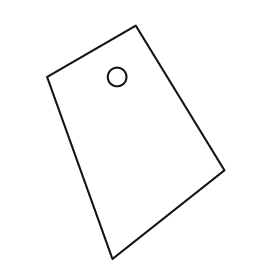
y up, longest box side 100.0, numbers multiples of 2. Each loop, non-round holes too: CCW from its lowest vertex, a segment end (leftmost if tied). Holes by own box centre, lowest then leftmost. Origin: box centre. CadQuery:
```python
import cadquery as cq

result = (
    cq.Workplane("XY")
    .moveTo(-10.0, -50.0)
    .lineTo(38.0, -12.0)
    .lineTo(0.0, 50.0)
    .lineTo(-38.0, 28.0)
    .close()
    .moveTo(-8.0, 28.0)
    .circle(4.0)
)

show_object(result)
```